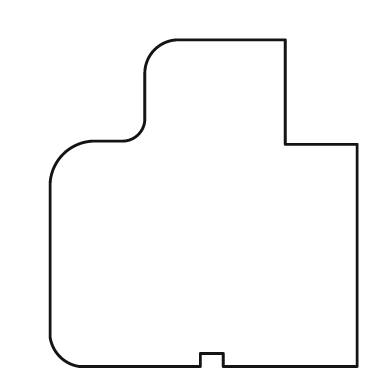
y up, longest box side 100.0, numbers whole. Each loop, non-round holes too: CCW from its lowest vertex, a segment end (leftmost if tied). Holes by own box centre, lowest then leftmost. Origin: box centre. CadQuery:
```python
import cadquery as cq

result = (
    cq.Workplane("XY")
    .moveTo(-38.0, -50.0)
    .lineTo(-1.0, -50.0)
    .lineTo(-1.0, -46.0)
    .lineTo(6.0, -46.0)
    .lineTo(6.0, -50.0)
    .lineTo(47.0, -50.0)
    .lineTo(47.0, 18.0)
    .lineTo(25.0, 18.0)
    .lineTo(25.0, 50.0)
    .lineTo(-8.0, 50.0)
    .threePointArc((-15.0, 47.0), (-18.0, 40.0))
    .lineTo(-18.0, 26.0)
    .threePointArc((-20.0, 21.0), (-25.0, 19.0))
    .lineTo(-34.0, 19.0)
    .threePointArc((-43.0, 15.0), (-47.0, 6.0))
    .lineTo(-47.0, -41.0)
    .threePointArc((-44.0, -47.0), (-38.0, -50.0))
    .close()
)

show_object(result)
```